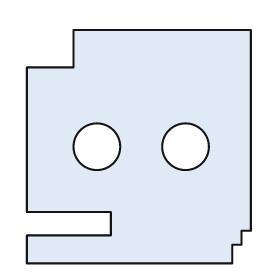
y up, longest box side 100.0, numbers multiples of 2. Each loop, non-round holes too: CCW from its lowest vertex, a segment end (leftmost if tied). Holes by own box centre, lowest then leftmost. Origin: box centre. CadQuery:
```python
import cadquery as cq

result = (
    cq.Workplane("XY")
    .moveTo(-48.0, -50.0)
    .lineTo(40.0, -50.0)
    .lineTo(40.0, -42.0)
    .lineTo(44.0, -42.0)
    .lineTo(44.0, -36.0)
    .lineTo(48.0, -36.0)
    .lineTo(48.0, 50.0)
    .lineTo(-28.0, 50.0)
    .lineTo(-28.0, 34.0)
    .lineTo(-48.0, 34.0)
    .lineTo(-48.0, -28.0)
    .lineTo(-12.0, -28.0)
    .lineTo(-12.0, -38.0)
    .lineTo(-48.0, -38.0)
    .close()
    .moveTo(-18.0, 0.0)
    .circle(10.0)
    .moveTo(20.0, 0.0)
    .circle(10.0)
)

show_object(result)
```